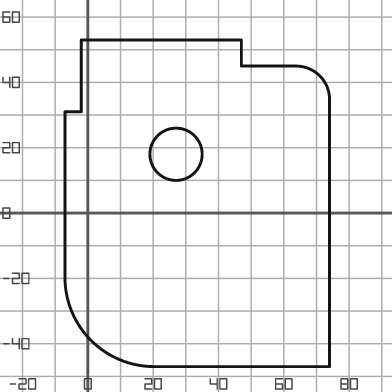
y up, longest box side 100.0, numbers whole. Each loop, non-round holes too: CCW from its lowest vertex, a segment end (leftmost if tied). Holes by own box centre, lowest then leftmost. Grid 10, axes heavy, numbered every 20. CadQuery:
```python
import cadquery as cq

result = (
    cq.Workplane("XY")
    .moveTo(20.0, -47.0)
    .lineTo(74.0, -47.0)
    .lineTo(74.0, 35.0)
    .threePointArc((71.0, 42.0), (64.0, 45.0))
    .lineTo(47.0, 45.0)
    .lineTo(47.0, 53.0)
    .lineTo(-2.0, 53.0)
    .lineTo(-2.0, 31.0)
    .lineTo(-7.0, 31.0)
    .lineTo(-7.0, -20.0)
    .threePointArc((1.0, -39.0), (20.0, -47.0))
    .close()
    .moveTo(27.0, 18.0)
    .circle(8.0)
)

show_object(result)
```